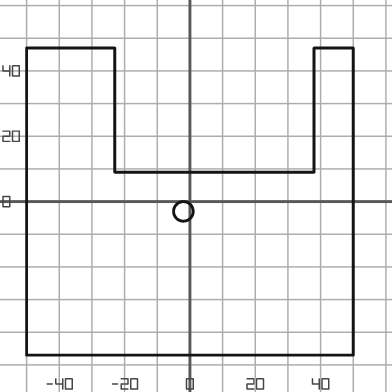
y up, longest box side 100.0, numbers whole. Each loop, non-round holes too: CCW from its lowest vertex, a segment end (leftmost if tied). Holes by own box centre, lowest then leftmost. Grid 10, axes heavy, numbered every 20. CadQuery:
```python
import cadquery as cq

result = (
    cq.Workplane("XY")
    .moveTo(-50.0, -47.0)
    .lineTo(50.0, -47.0)
    .lineTo(50.0, 47.0)
    .lineTo(38.0, 47.0)
    .lineTo(38.0, 9.0)
    .lineTo(-23.0, 9.0)
    .lineTo(-23.0, 47.0)
    .lineTo(-50.0, 47.0)
    .close()
    .moveTo(-2.0, -3.0)
    .circle(3.0)
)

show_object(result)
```